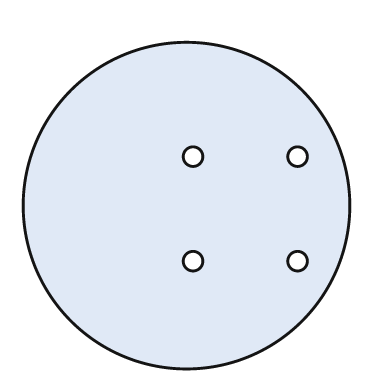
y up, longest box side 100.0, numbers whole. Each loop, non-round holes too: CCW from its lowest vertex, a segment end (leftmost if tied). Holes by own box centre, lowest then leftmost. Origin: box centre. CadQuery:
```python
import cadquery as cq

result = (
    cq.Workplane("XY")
    .moveTo(0.0, 0.0)
    .circle(50.0)
    .moveTo(2.0, -17.0)
    .circle(3.0)
    .moveTo(34.0, -17.0)
    .circle(3.0)
    .moveTo(2.0, 15.0)
    .circle(3.0)
    .moveTo(34.0, 15.0)
    .circle(3.0)
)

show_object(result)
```